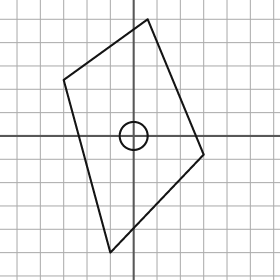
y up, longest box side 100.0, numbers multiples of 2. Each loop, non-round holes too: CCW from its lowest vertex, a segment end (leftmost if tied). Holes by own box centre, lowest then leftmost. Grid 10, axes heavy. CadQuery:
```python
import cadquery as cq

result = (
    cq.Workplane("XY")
    .moveTo(-10.0, -50.0)
    .lineTo(30.0, -8.0)
    .lineTo(6.0, 50.0)
    .lineTo(-30.0, 24.0)
    .close()
    .moveTo(0.0, 0.0)
    .circle(6.0)
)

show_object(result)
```